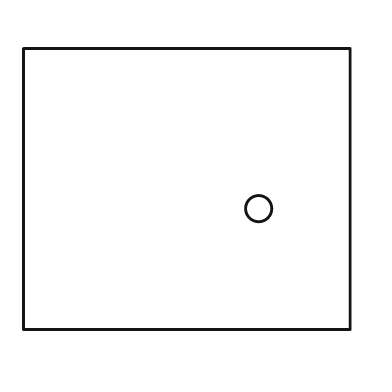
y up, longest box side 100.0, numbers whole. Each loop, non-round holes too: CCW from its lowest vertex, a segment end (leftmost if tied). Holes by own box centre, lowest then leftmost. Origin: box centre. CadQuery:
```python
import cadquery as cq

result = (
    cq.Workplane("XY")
    .moveTo(-50.0, -43.0)
    .lineTo(50.0, -43.0)
    .lineTo(50.0, 43.0)
    .lineTo(-50.0, 43.0)
    .close()
    .moveTo(22.0, -6.0)
    .circle(4.0)
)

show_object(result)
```